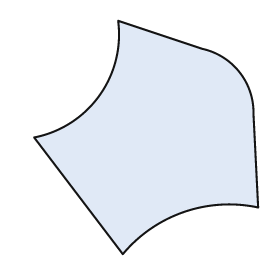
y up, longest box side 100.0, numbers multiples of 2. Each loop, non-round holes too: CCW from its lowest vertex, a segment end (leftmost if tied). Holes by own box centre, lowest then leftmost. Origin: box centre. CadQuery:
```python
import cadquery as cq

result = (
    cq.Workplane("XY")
    .moveTo(-10.0, -50.0)
    .threePointArc((16.0, -32.0), (48.0, -30.0))
    .lineTo(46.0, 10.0)
    .threePointArc((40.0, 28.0), (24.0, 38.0))
    .lineTo(-12.0, 50.0)
    .threePointArc((-20.0, 18.0), (-48.0, 0.0))
    .close()
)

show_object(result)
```